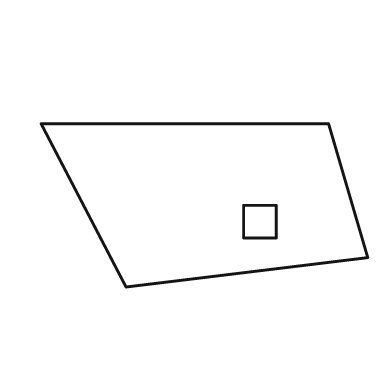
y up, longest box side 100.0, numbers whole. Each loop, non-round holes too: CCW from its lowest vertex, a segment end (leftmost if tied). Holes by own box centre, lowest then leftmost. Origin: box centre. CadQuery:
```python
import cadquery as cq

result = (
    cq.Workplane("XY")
    .moveTo(-24.0, -25.0)
    .lineTo(50.0, -16.0)
    .lineTo(38.0, 25.0)
    .lineTo(-50.0, 25.0)
    .close()
    .moveTo(12.0, -10.0)
    .lineTo(22.0, -10.0)
    .lineTo(22.0, 0.0)
    .lineTo(12.0, 0.0)
    .close()
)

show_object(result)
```